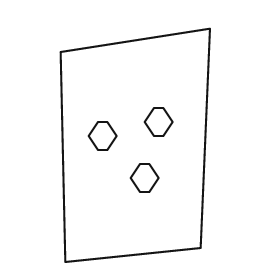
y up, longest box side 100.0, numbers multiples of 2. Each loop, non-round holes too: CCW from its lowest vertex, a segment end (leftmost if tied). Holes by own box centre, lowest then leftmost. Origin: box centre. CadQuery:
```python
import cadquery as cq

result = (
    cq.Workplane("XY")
    .moveTo(-30.0, -50.0)
    .lineTo(28.0, -44.0)
    .lineTo(32.0, 50.0)
    .lineTo(-32.0, 40.0)
    .close()
    .moveTo(2.0, -20.0)
    .lineTo(6.0, -20.0)
    .lineTo(10.0, -14.0)
    .lineTo(6.0, -8.0)
    .lineTo(2.0, -8.0)
    .lineTo(-2.0, -14.0)
    .close()
    .moveTo(-16.0, -2.0)
    .lineTo(-12.0, -2.0)
    .lineTo(-8.0, 4.0)
    .lineTo(-12.0, 10.0)
    .lineTo(-16.0, 10.0)
    .lineTo(-20.0, 4.0)
    .close()
    .moveTo(8.0, 4.0)
    .lineTo(12.0, 4.0)
    .lineTo(16.0, 10.0)
    .lineTo(12.0, 16.0)
    .lineTo(8.0, 16.0)
    .lineTo(4.0, 10.0)
    .close()
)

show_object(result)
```